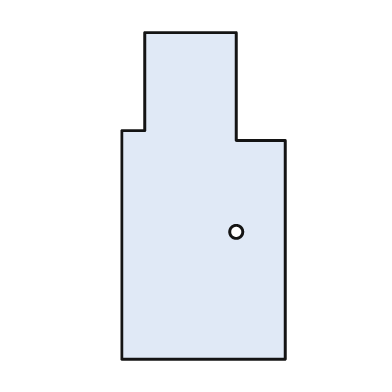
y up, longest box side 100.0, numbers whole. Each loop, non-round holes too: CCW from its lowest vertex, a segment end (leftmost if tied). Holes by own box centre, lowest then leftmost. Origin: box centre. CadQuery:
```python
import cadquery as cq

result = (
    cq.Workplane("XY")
    .moveTo(-25.0, -50.0)
    .lineTo(25.0, -50.0)
    .lineTo(25.0, 17.0)
    .lineTo(10.0, 17.0)
    .lineTo(10.0, 50.0)
    .lineTo(-18.0, 50.0)
    .lineTo(-18.0, 20.0)
    .lineTo(-25.0, 20.0)
    .close()
    .moveTo(10.0, -11.0)
    .circle(2.0)
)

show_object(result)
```